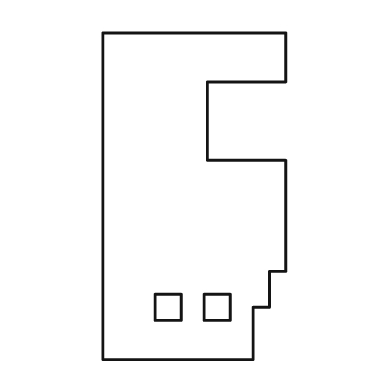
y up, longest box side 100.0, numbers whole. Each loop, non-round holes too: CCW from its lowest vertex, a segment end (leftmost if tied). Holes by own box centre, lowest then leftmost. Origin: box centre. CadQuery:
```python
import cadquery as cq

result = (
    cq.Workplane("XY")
    .moveTo(-28.0, -50.0)
    .lineTo(18.0, -50.0)
    .lineTo(18.0, -34.0)
    .lineTo(23.0, -34.0)
    .lineTo(23.0, -23.0)
    .lineTo(28.0, -23.0)
    .lineTo(28.0, 11.0)
    .lineTo(4.0, 11.0)
    .lineTo(4.0, 35.0)
    .lineTo(28.0, 35.0)
    .lineTo(28.0, 50.0)
    .lineTo(-28.0, 50.0)
    .close()
    .moveTo(-12.0, -38.0)
    .lineTo(-4.0, -38.0)
    .lineTo(-4.0, -30.0)
    .lineTo(-12.0, -30.0)
    .close()
    .moveTo(3.0, -38.0)
    .lineTo(11.0, -38.0)
    .lineTo(11.0, -30.0)
    .lineTo(3.0, -30.0)
    .close()
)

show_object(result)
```